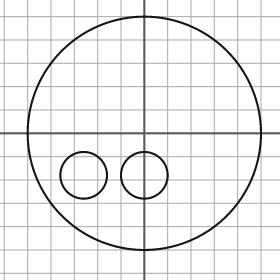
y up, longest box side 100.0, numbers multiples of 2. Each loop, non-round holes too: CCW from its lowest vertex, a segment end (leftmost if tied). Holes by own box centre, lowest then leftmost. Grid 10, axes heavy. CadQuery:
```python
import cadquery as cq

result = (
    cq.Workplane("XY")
    .moveTo(0.0, 0.0)
    .circle(50.0)
    .moveTo(-26.0, -18.0)
    .circle(10.0)
    .moveTo(0.0, -18.0)
    .circle(10.0)
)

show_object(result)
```